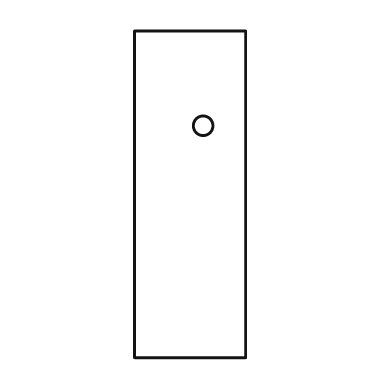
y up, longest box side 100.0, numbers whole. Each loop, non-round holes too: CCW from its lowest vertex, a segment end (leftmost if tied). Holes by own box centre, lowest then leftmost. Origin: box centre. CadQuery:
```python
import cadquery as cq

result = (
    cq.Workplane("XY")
    .moveTo(-17.0, -50.0)
    .lineTo(17.0, -50.0)
    .lineTo(17.0, 50.0)
    .lineTo(-17.0, 50.0)
    .close()
    .moveTo(4.0, 21.0)
    .circle(3.0)
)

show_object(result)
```